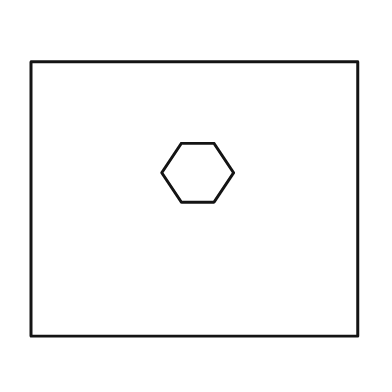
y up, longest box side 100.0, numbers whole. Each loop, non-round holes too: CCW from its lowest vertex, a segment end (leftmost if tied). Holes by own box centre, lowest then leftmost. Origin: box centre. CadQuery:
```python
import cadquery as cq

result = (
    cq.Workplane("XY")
    .moveTo(-50.0, -42.0)
    .lineTo(50.0, -42.0)
    .lineTo(50.0, 42.0)
    .lineTo(-50.0, 42.0)
    .close()
    .moveTo(-4.0, -1.0)
    .lineTo(6.0, -1.0)
    .lineTo(12.0, 8.0)
    .lineTo(6.0, 17.0)
    .lineTo(-4.0, 17.0)
    .lineTo(-10.0, 8.0)
    .close()
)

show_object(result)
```